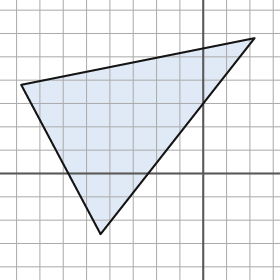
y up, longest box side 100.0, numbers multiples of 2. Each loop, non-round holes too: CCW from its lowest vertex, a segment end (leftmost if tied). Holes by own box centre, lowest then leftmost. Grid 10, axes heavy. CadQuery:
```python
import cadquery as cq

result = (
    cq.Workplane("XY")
    .moveTo(-44.0, -26.0)
    .lineTo(22.0, 58.0)
    .lineTo(-78.0, 38.0)
    .close()
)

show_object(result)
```